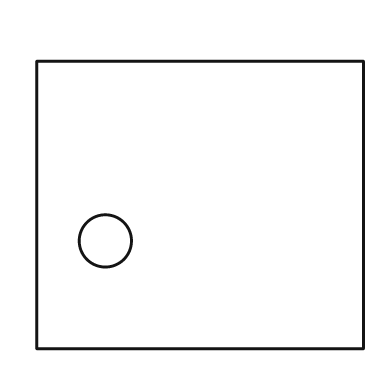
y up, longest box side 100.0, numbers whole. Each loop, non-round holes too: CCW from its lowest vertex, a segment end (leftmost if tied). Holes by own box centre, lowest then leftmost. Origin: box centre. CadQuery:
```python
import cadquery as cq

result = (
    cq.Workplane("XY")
    .moveTo(-50.0, -44.0)
    .lineTo(50.0, -44.0)
    .lineTo(50.0, 44.0)
    .lineTo(-50.0, 44.0)
    .close()
    .moveTo(-29.0, -11.0)
    .circle(8.0)
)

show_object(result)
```